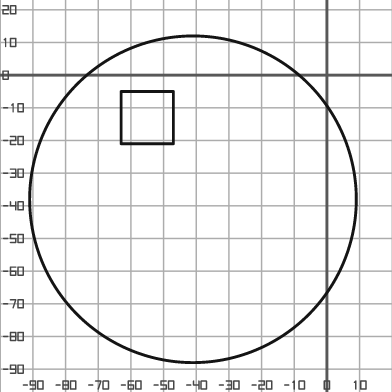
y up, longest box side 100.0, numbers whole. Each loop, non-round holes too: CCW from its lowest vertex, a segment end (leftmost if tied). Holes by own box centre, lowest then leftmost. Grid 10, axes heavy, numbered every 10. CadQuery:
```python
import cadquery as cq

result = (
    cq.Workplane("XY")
    .moveTo(-41.0, -38.0)
    .circle(50.0)
    .moveTo(-63.0, -21.0)
    .lineTo(-47.0, -21.0)
    .lineTo(-47.0, -5.0)
    .lineTo(-63.0, -5.0)
    .close()
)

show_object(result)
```